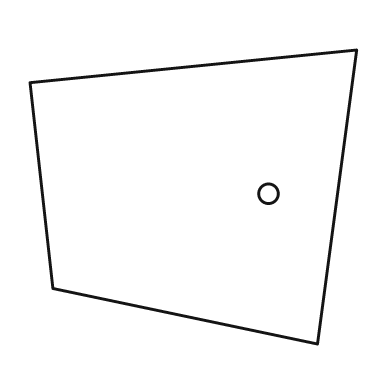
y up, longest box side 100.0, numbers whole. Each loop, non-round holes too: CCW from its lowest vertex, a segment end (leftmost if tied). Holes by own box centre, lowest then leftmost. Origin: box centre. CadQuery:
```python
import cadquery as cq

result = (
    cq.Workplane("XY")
    .moveTo(38.0, -45.0)
    .lineTo(50.0, 45.0)
    .lineTo(-50.0, 35.0)
    .lineTo(-43.0, -28.0)
    .close()
    .moveTo(23.0, 1.0)
    .circle(3.0)
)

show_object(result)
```